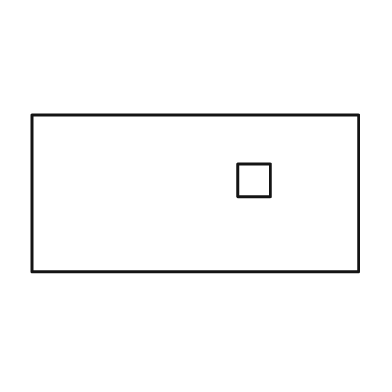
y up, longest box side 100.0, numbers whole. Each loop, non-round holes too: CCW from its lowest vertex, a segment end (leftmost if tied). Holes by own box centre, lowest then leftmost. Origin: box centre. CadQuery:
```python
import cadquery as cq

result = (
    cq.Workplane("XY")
    .moveTo(-50.0, -24.0)
    .lineTo(50.0, -24.0)
    .lineTo(50.0, 24.0)
    .lineTo(-50.0, 24.0)
    .close()
    .moveTo(13.0, -1.0)
    .lineTo(23.0, -1.0)
    .lineTo(23.0, 9.0)
    .lineTo(13.0, 9.0)
    .close()
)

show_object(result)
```